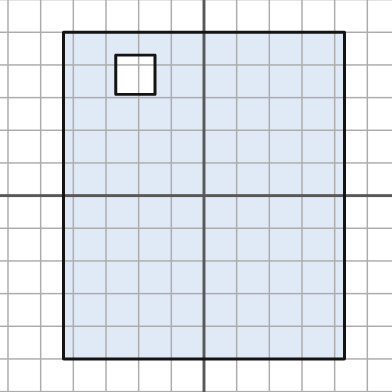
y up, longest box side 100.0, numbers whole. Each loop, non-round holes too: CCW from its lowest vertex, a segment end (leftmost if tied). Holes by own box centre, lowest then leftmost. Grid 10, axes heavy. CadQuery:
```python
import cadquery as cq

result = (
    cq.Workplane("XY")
    .moveTo(-43.0, -50.0)
    .lineTo(43.0, -50.0)
    .lineTo(43.0, 50.0)
    .lineTo(-43.0, 50.0)
    .close()
    .moveTo(-27.0, 31.0)
    .lineTo(-15.0, 31.0)
    .lineTo(-15.0, 43.0)
    .lineTo(-27.0, 43.0)
    .close()
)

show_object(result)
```